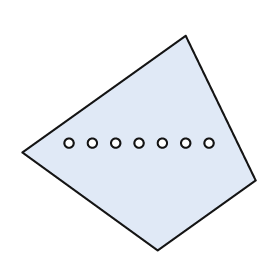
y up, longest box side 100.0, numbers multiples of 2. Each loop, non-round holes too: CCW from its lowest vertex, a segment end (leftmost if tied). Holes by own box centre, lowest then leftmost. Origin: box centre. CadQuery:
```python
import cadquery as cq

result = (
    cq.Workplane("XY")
    .moveTo(8.0, -46.0)
    .lineTo(50.0, -16.0)
    .lineTo(20.0, 46.0)
    .lineTo(-50.0, -4.0)
    .close()
    .moveTo(-30.0, 0.0)
    .circle(2.0)
    .moveTo(-20.0, 0.0)
    .circle(2.0)
    .moveTo(-10.0, 0.0)
    .circle(2.0)
    .moveTo(0.0, 0.0)
    .circle(2.0)
    .moveTo(10.0, 0.0)
    .circle(2.0)
    .moveTo(20.0, 0.0)
    .circle(2.0)
    .moveTo(30.0, 0.0)
    .circle(2.0)
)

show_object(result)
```